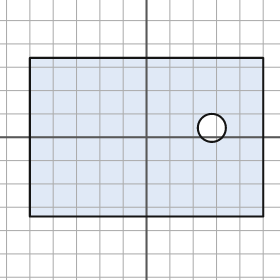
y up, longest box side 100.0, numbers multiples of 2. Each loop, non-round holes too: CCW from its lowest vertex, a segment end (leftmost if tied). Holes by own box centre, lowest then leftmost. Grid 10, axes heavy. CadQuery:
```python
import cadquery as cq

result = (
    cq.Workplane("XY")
    .moveTo(-50.0, -34.0)
    .lineTo(50.0, -34.0)
    .lineTo(50.0, 34.0)
    .lineTo(-50.0, 34.0)
    .close()
    .moveTo(28.0, 4.0)
    .circle(6.0)
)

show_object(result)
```